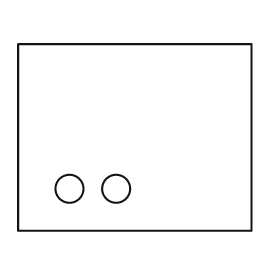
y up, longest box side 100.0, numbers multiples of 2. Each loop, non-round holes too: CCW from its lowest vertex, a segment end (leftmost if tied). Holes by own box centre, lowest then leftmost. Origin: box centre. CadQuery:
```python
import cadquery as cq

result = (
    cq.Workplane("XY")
    .moveTo(-50.0, -40.0)
    .lineTo(50.0, -40.0)
    .lineTo(50.0, 40.0)
    .lineTo(-50.0, 40.0)
    .close()
    .moveTo(-28.0, -22.0)
    .circle(6.0)
    .moveTo(-8.0, -22.0)
    .circle(6.0)
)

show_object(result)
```